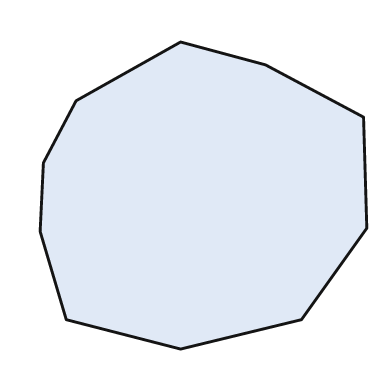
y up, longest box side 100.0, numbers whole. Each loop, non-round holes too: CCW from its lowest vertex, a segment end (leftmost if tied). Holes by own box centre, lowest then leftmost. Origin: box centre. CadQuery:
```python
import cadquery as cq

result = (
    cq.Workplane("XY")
    .moveTo(-7.0, -47.0)
    .lineTo(30.0, -38.0)
    .lineTo(50.0, -10.0)
    .lineTo(49.0, 24.0)
    .lineTo(19.0, 40.0)
    .lineTo(-7.0, 47.0)
    .lineTo(-39.0, 29.0)
    .lineTo(-49.0, 10.0)
    .lineTo(-50.0, -11.0)
    .lineTo(-42.0, -38.0)
    .close()
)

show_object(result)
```